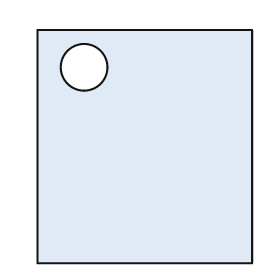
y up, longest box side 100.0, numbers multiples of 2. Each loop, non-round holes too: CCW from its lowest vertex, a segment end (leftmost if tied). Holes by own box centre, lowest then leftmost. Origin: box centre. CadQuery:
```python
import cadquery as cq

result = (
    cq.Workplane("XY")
    .moveTo(-46.0, -50.0)
    .lineTo(46.0, -50.0)
    .lineTo(46.0, 50.0)
    .lineTo(-46.0, 50.0)
    .close()
    .moveTo(-26.0, 34.0)
    .circle(10.0)
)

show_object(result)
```